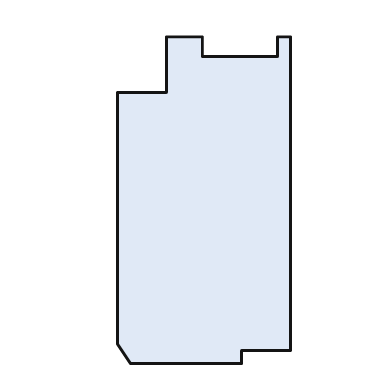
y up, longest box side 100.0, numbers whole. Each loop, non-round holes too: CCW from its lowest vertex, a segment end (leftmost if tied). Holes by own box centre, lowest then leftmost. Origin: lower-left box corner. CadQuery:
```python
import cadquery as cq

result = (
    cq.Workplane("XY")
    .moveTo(4.0, 0.0)
    .lineTo(38.0, 0.0)
    .lineTo(38.0, 4.0)
    .lineTo(53.0, 4.0)
    .lineTo(53.0, 100.0)
    .lineTo(49.0, 100.0)
    .lineTo(49.0, 94.0)
    .lineTo(26.0, 94.0)
    .lineTo(26.0, 100.0)
    .lineTo(15.0, 100.0)
    .lineTo(15.0, 83.0)
    .lineTo(0.0, 83.0)
    .lineTo(0.0, 6.0)
    .close()
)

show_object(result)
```